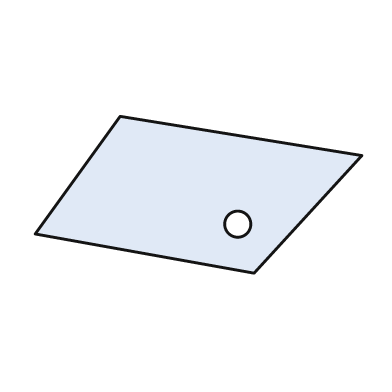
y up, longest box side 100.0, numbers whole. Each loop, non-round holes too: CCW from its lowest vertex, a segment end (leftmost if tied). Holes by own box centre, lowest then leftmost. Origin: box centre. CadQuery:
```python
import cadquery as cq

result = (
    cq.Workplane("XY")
    .moveTo(17.0, -24.0)
    .lineTo(50.0, 12.0)
    .lineTo(-24.0, 24.0)
    .lineTo(-50.0, -12.0)
    .close()
    .moveTo(12.0, -9.0)
    .circle(4.0)
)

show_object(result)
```